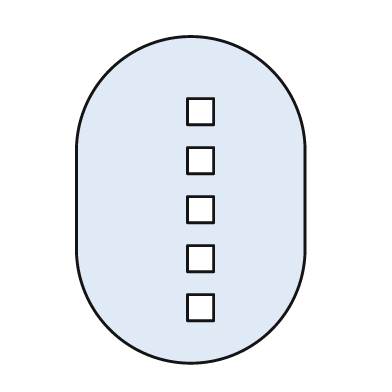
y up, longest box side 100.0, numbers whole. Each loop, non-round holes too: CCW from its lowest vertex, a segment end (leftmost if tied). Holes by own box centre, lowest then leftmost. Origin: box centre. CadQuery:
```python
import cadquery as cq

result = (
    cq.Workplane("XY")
    .moveTo(-35.0, -15.0)
    .threePointArc((0.0, -50.0), (35.0, -15.0))
    .lineTo(35.0, 15.0)
    .threePointArc((0.0, 50.0), (-35.0, 15.0))
    .close()
    .moveTo(-1.0, -37.0)
    .lineTo(7.0, -37.0)
    .lineTo(7.0, -29.0)
    .lineTo(-1.0, -29.0)
    .close()
    .moveTo(-1.0, -22.0)
    .lineTo(7.0, -22.0)
    .lineTo(7.0, -14.0)
    .lineTo(-1.0, -14.0)
    .close()
    .moveTo(-1.0, -7.0)
    .lineTo(7.0, -7.0)
    .lineTo(7.0, 1.0)
    .lineTo(-1.0, 1.0)
    .close()
    .moveTo(-1.0, 8.0)
    .lineTo(7.0, 8.0)
    .lineTo(7.0, 16.0)
    .lineTo(-1.0, 16.0)
    .close()
    .moveTo(-1.0, 23.0)
    .lineTo(7.0, 23.0)
    .lineTo(7.0, 31.0)
    .lineTo(-1.0, 31.0)
    .close()
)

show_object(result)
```